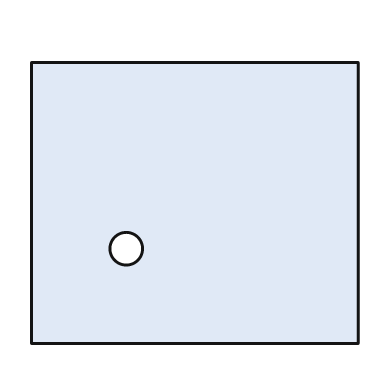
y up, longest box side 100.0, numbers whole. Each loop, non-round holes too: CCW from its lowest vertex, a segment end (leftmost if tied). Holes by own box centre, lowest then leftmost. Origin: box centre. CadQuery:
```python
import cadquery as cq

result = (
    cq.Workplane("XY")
    .moveTo(-50.0, -43.0)
    .lineTo(50.0, -43.0)
    .lineTo(50.0, 43.0)
    .lineTo(-50.0, 43.0)
    .close()
    .moveTo(-21.0, -14.0)
    .circle(5.0)
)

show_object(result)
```